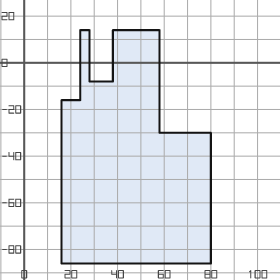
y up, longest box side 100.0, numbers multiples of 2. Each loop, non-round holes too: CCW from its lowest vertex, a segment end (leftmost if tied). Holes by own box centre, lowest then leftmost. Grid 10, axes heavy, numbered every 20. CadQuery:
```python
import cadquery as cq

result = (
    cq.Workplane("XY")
    .moveTo(16.0, -86.0)
    .lineTo(80.0, -86.0)
    .lineTo(80.0, -30.0)
    .lineTo(58.0, -30.0)
    .lineTo(58.0, 14.0)
    .lineTo(38.0, 14.0)
    .lineTo(38.0, -8.0)
    .lineTo(28.0, -8.0)
    .lineTo(28.0, 14.0)
    .lineTo(24.0, 14.0)
    .lineTo(24.0, -16.0)
    .lineTo(16.0, -16.0)
    .close()
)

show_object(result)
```